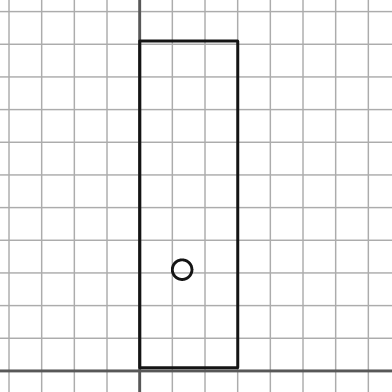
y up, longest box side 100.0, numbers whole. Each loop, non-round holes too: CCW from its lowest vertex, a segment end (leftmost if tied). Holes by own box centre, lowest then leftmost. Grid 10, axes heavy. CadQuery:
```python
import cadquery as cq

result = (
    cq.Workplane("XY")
    .moveTo(0.0, 1.0)
    .lineTo(30.0, 1.0)
    .lineTo(30.0, 101.0)
    .lineTo(0.0, 101.0)
    .close()
    .moveTo(13.0, 31.0)
    .circle(3.0)
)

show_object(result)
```